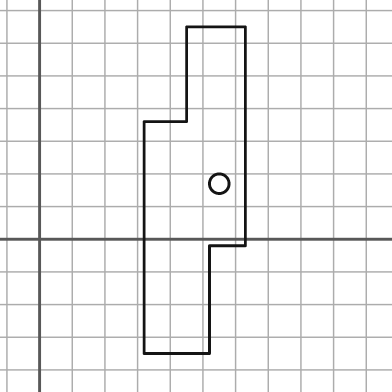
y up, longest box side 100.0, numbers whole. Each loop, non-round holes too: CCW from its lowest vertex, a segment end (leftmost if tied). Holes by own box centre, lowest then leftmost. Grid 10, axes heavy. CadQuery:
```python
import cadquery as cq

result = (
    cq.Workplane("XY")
    .moveTo(32.0, -35.0)
    .lineTo(52.0, -35.0)
    .lineTo(52.0, -2.0)
    .lineTo(63.0, -2.0)
    .lineTo(63.0, 65.0)
    .lineTo(45.0, 65.0)
    .lineTo(45.0, 36.0)
    .lineTo(32.0, 36.0)
    .close()
    .moveTo(55.0, 17.0)
    .circle(3.0)
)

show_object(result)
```